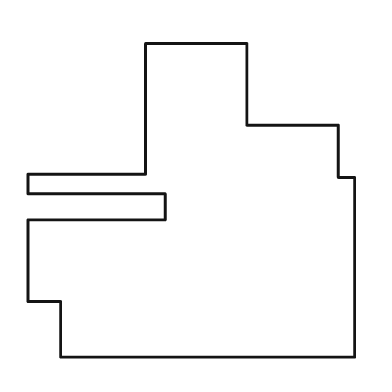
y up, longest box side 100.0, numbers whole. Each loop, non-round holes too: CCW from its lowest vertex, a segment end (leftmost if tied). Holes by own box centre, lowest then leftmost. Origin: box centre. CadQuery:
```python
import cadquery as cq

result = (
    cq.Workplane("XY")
    .moveTo(-40.0, -48.0)
    .lineTo(50.0, -48.0)
    .lineTo(50.0, 7.0)
    .lineTo(45.0, 7.0)
    .lineTo(45.0, 23.0)
    .lineTo(17.0, 23.0)
    .lineTo(17.0, 48.0)
    .lineTo(-14.0, 48.0)
    .lineTo(-14.0, 8.0)
    .lineTo(-50.0, 8.0)
    .lineTo(-50.0, 2.0)
    .lineTo(-8.0, 2.0)
    .lineTo(-8.0, -6.0)
    .lineTo(-50.0, -6.0)
    .lineTo(-50.0, -31.0)
    .lineTo(-40.0, -31.0)
    .close()
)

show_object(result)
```